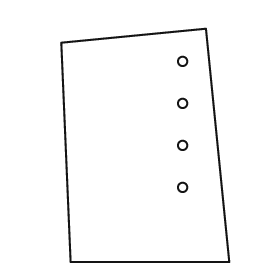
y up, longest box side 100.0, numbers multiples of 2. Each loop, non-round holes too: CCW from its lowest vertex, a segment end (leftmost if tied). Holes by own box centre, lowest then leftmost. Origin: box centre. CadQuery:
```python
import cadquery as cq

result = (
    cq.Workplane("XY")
    .moveTo(-32.0, -50.0)
    .lineTo(36.0, -50.0)
    .lineTo(26.0, 50.0)
    .lineTo(-36.0, 44.0)
    .close()
    .moveTo(16.0, -18.0)
    .circle(2.0)
    .moveTo(16.0, 0.0)
    .circle(2.0)
    .moveTo(16.0, 18.0)
    .circle(2.0)
    .moveTo(16.0, 36.0)
    .circle(2.0)
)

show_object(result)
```